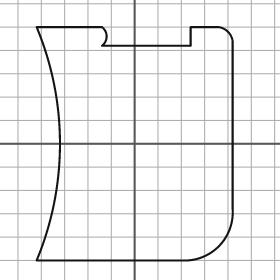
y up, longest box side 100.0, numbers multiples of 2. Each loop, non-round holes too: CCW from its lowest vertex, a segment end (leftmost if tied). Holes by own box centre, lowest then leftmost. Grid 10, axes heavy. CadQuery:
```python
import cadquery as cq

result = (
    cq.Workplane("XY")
    .moveTo(-42.0, -50.0)
    .lineTo(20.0, -50.0)
    .threePointArc((36.0, -44.0), (42.0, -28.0))
    .lineTo(42.0, 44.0)
    .threePointArc((40.0, 48.0), (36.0, 50.0))
    .lineTo(24.0, 50.0)
    .lineTo(24.0, 42.0)
    .lineTo(-14.0, 42.0)
    .threePointArc((-12.0, 46.0), (-14.0, 50.0))
    .lineTo(-42.0, 50.0)
    .threePointArc((-32.0, 0.0), (-42.0, -50.0))
    .close()
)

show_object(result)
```